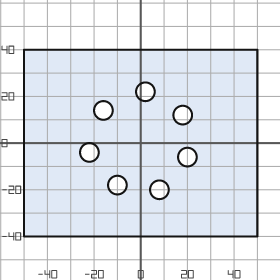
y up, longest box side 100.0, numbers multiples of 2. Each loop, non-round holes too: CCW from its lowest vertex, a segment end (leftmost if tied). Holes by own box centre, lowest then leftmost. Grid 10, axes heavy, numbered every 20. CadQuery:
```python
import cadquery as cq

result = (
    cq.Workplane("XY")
    .moveTo(-50.0, -40.0)
    .lineTo(50.0, -40.0)
    .lineTo(50.0, 40.0)
    .lineTo(-50.0, 40.0)
    .close()
    .moveTo(8.0, -20.0)
    .circle(4.0)
    .moveTo(-10.0, -18.0)
    .circle(4.0)
    .moveTo(20.0, -6.0)
    .circle(4.0)
    .moveTo(-22.0, -4.0)
    .circle(4.0)
    .moveTo(18.0, 12.0)
    .circle(4.0)
    .moveTo(-16.0, 14.0)
    .circle(4.0)
    .moveTo(2.0, 22.0)
    .circle(4.0)
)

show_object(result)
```